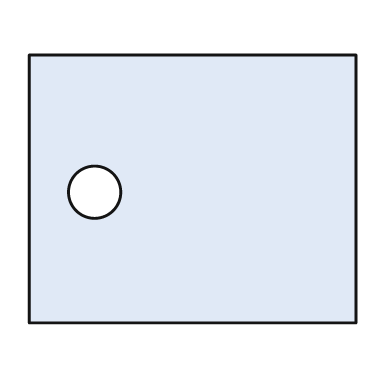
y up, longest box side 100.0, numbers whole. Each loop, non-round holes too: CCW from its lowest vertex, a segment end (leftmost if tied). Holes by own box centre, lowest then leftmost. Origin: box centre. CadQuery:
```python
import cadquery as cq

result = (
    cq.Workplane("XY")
    .moveTo(-50.0, -41.0)
    .lineTo(50.0, -41.0)
    .lineTo(50.0, 41.0)
    .lineTo(-50.0, 41.0)
    .close()
    .moveTo(-30.0, -1.0)
    .circle(8.0)
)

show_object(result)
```